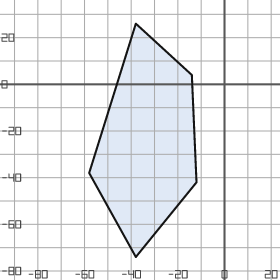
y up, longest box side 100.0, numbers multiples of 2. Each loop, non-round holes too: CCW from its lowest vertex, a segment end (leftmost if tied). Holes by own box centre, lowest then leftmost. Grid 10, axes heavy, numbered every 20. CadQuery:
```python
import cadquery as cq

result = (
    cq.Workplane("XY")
    .moveTo(-38.0, -74.0)
    .lineTo(-12.0, -42.0)
    .lineTo(-14.0, 4.0)
    .lineTo(-38.0, 26.0)
    .lineTo(-58.0, -38.0)
    .close()
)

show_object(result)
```